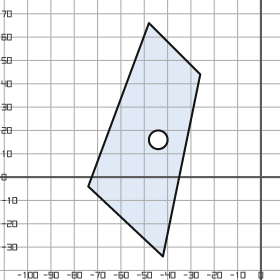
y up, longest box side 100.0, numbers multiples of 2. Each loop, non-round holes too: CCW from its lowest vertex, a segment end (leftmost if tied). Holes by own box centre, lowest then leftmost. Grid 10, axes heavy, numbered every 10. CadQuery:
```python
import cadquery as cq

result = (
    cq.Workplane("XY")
    .moveTo(-42.0, -34.0)
    .lineTo(-26.0, 44.0)
    .lineTo(-48.0, 66.0)
    .lineTo(-74.0, -4.0)
    .close()
    .moveTo(-44.0, 16.0)
    .circle(4.0)
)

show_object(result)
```